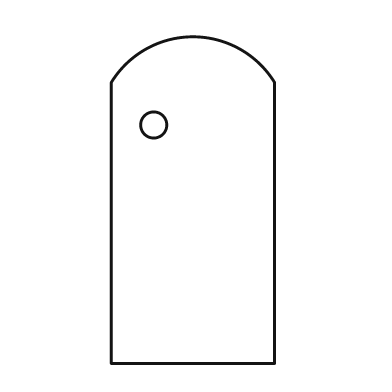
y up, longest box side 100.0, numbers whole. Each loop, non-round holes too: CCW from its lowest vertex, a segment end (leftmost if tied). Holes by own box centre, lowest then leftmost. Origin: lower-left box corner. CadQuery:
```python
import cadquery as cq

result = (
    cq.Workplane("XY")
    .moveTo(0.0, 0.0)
    .lineTo(50.0, 0.0)
    .lineTo(50.0, 86.0)
    .threePointArc((25.0, 100.0), (0.0, 86.0))
    .close()
    .moveTo(13.0, 73.0)
    .circle(4.0)
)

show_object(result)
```